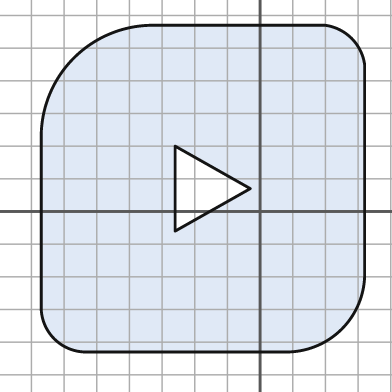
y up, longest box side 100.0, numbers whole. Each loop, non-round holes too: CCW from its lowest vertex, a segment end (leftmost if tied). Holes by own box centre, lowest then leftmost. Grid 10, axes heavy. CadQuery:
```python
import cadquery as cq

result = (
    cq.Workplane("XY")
    .moveTo(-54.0, -43.0)
    .lineTo(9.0, -43.0)
    .threePointArc((25.0, -36.0), (32.0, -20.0))
    .lineTo(32.0, 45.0)
    .threePointArc((28.0, 53.0), (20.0, 57.0))
    .lineTo(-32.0, 57.0)
    .threePointArc((-57.0, 47.0), (-67.0, 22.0))
    .lineTo(-67.0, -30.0)
    .threePointArc((-63.0, -39.0), (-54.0, -43.0))
    .close()
    .moveTo(-26.0, -6.0)
    .lineTo(-3.0, 7.0)
    .lineTo(-26.0, 20.0)
    .close()
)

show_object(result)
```